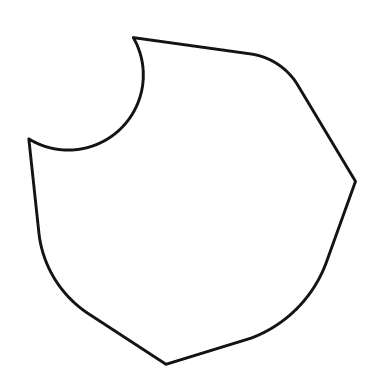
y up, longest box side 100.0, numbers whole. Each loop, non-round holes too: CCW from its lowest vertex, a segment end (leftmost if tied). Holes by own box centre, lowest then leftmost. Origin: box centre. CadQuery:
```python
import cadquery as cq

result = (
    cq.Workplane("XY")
    .moveTo(-8.0, -50.0)
    .lineTo(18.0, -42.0)
    .threePointArc((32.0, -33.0), (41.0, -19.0))
    .lineTo(50.0, 6.0)
    .lineTo(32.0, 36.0)
    .threePointArc((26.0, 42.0), (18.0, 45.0))
    .lineTo(-18.0, 50.0)
    .threePointArc((-22.0, 22.0), (-50.0, 19.0))
    .lineTo(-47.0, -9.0)
    .threePointArc((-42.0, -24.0), (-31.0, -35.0))
    .close()
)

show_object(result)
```